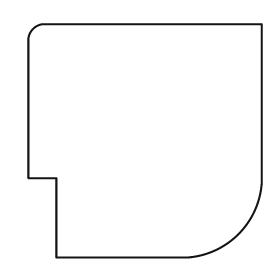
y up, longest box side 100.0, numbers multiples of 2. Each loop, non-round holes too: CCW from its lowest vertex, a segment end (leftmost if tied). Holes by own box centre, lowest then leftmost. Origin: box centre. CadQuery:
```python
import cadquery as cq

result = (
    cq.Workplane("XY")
    .moveTo(-38.0, -50.0)
    .lineTo(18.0, -50.0)
    .threePointArc((40.0, -40.0), (50.0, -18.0))
    .lineTo(50.0, 50.0)
    .lineTo(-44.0, 50.0)
    .threePointArc((-48.0, 48.0), (-50.0, 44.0))
    .lineTo(-50.0, -16.0)
    .lineTo(-38.0, -16.0)
    .close()
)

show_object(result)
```